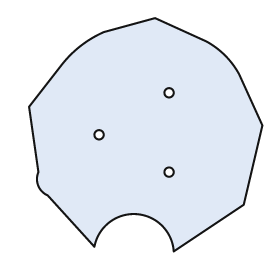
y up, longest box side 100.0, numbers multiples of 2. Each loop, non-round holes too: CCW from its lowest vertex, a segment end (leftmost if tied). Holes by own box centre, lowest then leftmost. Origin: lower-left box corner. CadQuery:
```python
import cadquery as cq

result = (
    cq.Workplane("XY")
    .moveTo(62.0, 0.0)
    .lineTo(92.0, 20.0)
    .lineTo(100.0, 54.0)
    .lineTo(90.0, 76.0)
    .threePointArc((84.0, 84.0), (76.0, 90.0))
    .lineTo(54.0, 100.0)
    .lineTo(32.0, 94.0)
    .threePointArc((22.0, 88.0), (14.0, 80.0))
    .lineTo(0.0, 62.0)
    .lineTo(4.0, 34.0)
    .threePointArc((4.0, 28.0), (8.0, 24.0))
    .lineTo(28.0, 2.0)
    .threePointArc((46.0, 16.0), (62.0, 0.0))
    .close()
    .moveTo(60.0, 34.0)
    .circle(2.0)
    .moveTo(30.0, 50.0)
    .circle(2.0)
    .moveTo(60.0, 68.0)
    .circle(2.0)
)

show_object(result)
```